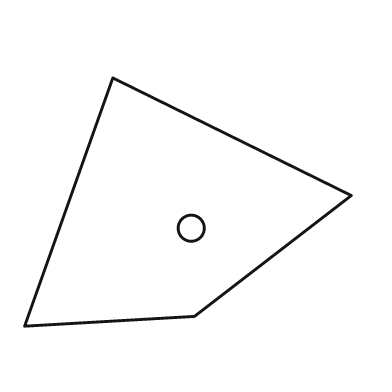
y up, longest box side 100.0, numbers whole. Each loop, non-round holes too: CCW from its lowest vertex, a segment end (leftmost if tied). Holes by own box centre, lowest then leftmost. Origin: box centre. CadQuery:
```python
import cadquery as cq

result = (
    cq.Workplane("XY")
    .moveTo(-50.0, -38.0)
    .lineTo(2.0, -35.0)
    .lineTo(50.0, 2.0)
    .lineTo(-23.0, 38.0)
    .close()
    .moveTo(1.0, -8.0)
    .circle(4.0)
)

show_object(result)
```